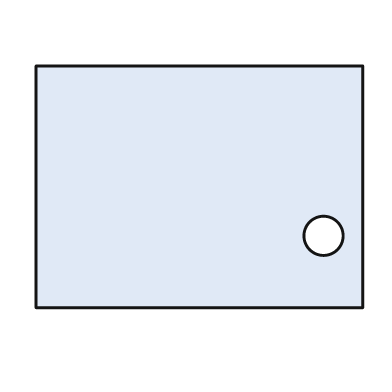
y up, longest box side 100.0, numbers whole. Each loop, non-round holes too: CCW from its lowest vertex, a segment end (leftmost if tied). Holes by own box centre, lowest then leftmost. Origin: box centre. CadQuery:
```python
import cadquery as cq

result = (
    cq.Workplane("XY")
    .moveTo(-50.0, -37.0)
    .lineTo(50.0, -37.0)
    .lineTo(50.0, 37.0)
    .lineTo(-50.0, 37.0)
    .close()
    .moveTo(38.0, -15.0)
    .circle(6.0)
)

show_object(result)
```